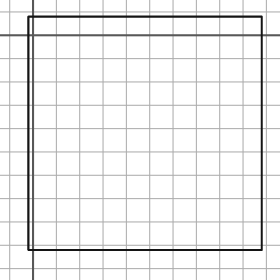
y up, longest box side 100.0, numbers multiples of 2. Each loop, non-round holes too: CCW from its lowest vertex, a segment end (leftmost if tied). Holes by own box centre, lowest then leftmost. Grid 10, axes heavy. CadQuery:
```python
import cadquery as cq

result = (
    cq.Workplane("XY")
    .moveTo(-2.0, -92.0)
    .lineTo(98.0, -92.0)
    .lineTo(98.0, 8.0)
    .lineTo(-2.0, 8.0)
    .close()
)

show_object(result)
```